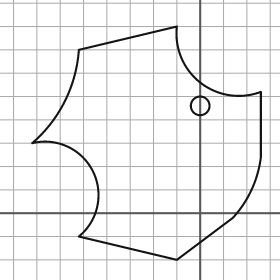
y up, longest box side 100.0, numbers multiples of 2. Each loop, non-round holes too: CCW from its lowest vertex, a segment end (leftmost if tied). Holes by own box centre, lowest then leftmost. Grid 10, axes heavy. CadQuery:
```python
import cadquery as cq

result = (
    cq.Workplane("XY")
    .moveTo(-10.0, -20.0)
    .lineTo(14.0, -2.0)
    .threePointArc((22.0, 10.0), (26.0, 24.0))
    .lineTo(26.0, 52.0)
    .threePointArc((0.0, 56.0), (-10.0, 80.0))
    .lineTo(-52.0, 70.0)
    .threePointArc((-58.0, 48.0), (-72.0, 30.0))
    .threePointArc((-46.0, 18.0), (-52.0, -10.0))
    .close()
    .moveTo(0.0, 46.0)
    .circle(4.0)
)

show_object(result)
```